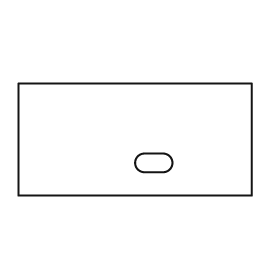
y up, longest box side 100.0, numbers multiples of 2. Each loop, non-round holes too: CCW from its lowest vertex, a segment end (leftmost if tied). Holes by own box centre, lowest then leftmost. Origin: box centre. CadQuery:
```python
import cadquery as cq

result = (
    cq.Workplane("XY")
    .moveTo(-50.0, -24.0)
    .lineTo(50.0, -24.0)
    .lineTo(50.0, 24.0)
    .lineTo(-50.0, 24.0)
    .close()
    .moveTo(4.0, -14.0)
    .lineTo(12.0, -14.0)
    .threePointArc((16.0, -10.0), (12.0, -6.0))
    .lineTo(4.0, -6.0)
    .threePointArc((0.0, -10.0), (4.0, -14.0))
    .close()
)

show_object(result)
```